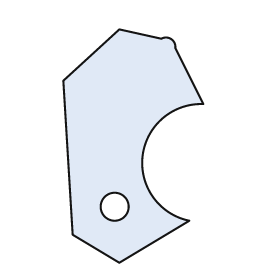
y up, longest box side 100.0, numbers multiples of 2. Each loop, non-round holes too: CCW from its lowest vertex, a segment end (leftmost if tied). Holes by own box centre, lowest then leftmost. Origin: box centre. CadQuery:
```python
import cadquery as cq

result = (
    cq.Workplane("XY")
    .moveTo(-6.0, -50.0)
    .lineTo(24.0, -32.0)
    .threePointArc((4.0, -4.0), (30.0, 18.0))
    .lineTo(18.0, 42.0)
    .threePointArc((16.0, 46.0), (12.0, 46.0))
    .lineTo(-6.0, 50.0)
    .lineTo(-30.0, 28.0)
    .lineTo(-26.0, -38.0)
    .close()
    .moveTo(-8.0, -26.0)
    .circle(6.0)
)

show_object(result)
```